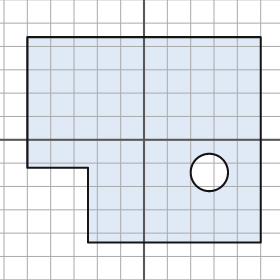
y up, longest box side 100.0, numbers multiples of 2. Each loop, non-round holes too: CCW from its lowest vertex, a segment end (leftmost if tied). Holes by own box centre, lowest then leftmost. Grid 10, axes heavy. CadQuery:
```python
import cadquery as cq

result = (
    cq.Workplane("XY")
    .moveTo(-24.0, -44.0)
    .lineTo(50.0, -44.0)
    .lineTo(50.0, 44.0)
    .lineTo(-50.0, 44.0)
    .lineTo(-50.0, -12.0)
    .lineTo(-24.0, -12.0)
    .close()
    .moveTo(28.0, -14.0)
    .circle(8.0)
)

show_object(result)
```